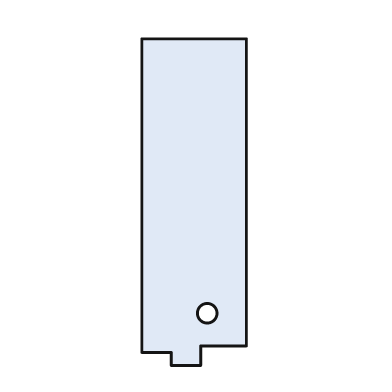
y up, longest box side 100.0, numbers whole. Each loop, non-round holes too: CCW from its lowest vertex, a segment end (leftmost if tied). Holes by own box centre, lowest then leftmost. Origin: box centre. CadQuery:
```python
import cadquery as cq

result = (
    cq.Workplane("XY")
    .moveTo(-7.0, -50.0)
    .lineTo(2.0, -50.0)
    .lineTo(2.0, -44.0)
    .lineTo(16.0, -44.0)
    .lineTo(16.0, 50.0)
    .lineTo(-16.0, 50.0)
    .lineTo(-16.0, -46.0)
    .lineTo(-7.0, -46.0)
    .close()
    .moveTo(4.0, -34.0)
    .circle(3.0)
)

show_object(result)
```